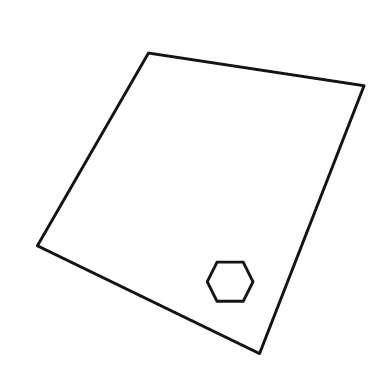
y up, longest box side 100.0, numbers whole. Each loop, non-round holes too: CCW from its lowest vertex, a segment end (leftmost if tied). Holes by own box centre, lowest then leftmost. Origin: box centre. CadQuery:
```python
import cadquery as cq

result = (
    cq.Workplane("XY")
    .moveTo(18.0, -46.0)
    .lineTo(50.0, 36.0)
    .lineTo(-16.0, 46.0)
    .lineTo(-50.0, -13.0)
    .close()
    .moveTo(5.0, -30.0)
    .lineTo(13.0, -30.0)
    .lineTo(16.0, -24.0)
    .lineTo(13.0, -18.0)
    .lineTo(5.0, -18.0)
    .lineTo(2.0, -24.0)
    .close()
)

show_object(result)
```